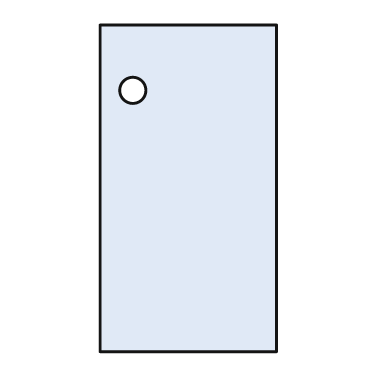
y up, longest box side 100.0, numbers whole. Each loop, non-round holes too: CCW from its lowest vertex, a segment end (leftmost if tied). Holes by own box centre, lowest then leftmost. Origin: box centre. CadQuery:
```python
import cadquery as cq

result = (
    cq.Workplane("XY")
    .moveTo(-27.0, -50.0)
    .lineTo(27.0, -50.0)
    .lineTo(27.0, 50.0)
    .lineTo(-27.0, 50.0)
    .close()
    .moveTo(-17.0, 30.0)
    .circle(4.0)
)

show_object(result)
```